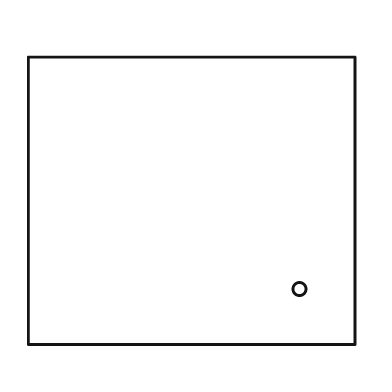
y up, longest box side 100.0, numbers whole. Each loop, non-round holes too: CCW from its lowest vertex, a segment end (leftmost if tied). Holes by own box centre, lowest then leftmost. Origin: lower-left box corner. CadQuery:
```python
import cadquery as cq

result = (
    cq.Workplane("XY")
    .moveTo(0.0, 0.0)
    .lineTo(100.0, 0.0)
    .lineTo(100.0, 88.0)
    .lineTo(0.0, 88.0)
    .close()
    .moveTo(83.0, 17.0)
    .circle(2.0)
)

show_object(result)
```